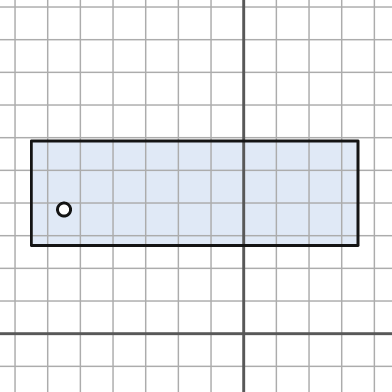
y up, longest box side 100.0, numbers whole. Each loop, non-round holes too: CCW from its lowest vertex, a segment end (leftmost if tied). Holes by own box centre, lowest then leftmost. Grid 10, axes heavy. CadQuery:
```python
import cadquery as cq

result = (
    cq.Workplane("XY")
    .moveTo(-65.0, 27.0)
    .lineTo(35.0, 27.0)
    .lineTo(35.0, 59.0)
    .lineTo(-65.0, 59.0)
    .close()
    .moveTo(-55.0, 38.0)
    .circle(2.0)
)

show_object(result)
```